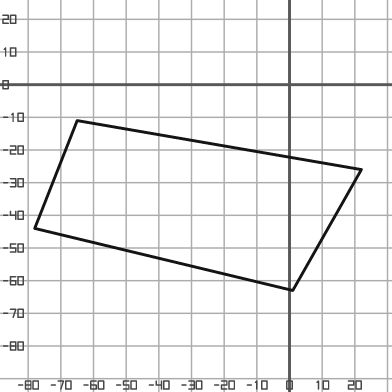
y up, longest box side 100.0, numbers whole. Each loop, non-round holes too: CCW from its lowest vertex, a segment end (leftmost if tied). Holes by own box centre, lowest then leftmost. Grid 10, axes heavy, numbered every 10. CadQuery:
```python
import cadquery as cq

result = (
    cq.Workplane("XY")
    .moveTo(1.0, -63.0)
    .lineTo(22.0, -26.0)
    .lineTo(-65.0, -11.0)
    .lineTo(-78.0, -44.0)
    .close()
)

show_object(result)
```